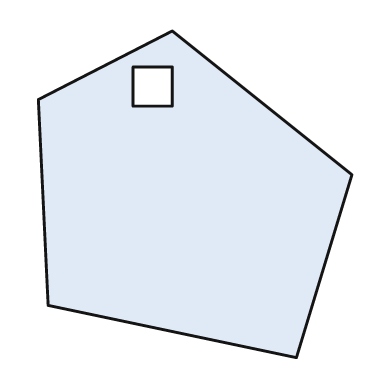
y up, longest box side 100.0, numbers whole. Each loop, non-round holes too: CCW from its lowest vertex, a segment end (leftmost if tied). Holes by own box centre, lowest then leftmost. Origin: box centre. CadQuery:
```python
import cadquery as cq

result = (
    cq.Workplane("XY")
    .moveTo(31.0, -50.0)
    .lineTo(48.0, 6.0)
    .lineTo(-7.0, 50.0)
    .lineTo(-48.0, 29.0)
    .lineTo(-45.0, -34.0)
    .close()
    .moveTo(-19.0, 27.0)
    .lineTo(-7.0, 27.0)
    .lineTo(-7.0, 39.0)
    .lineTo(-19.0, 39.0)
    .close()
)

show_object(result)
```